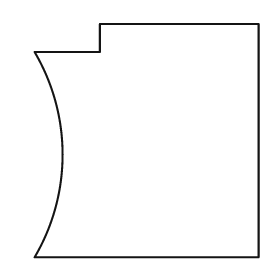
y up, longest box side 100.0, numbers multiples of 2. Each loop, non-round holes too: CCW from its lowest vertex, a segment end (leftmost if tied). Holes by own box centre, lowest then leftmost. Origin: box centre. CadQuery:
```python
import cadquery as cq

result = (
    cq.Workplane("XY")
    .moveTo(-48.0, -50.0)
    .lineTo(48.0, -50.0)
    .lineTo(48.0, 50.0)
    .lineTo(-20.0, 50.0)
    .lineTo(-20.0, 38.0)
    .lineTo(-48.0, 38.0)
    .threePointArc((-36.0, -6.0), (-48.0, -50.0))
    .close()
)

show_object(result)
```